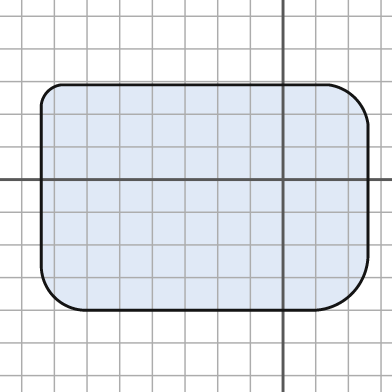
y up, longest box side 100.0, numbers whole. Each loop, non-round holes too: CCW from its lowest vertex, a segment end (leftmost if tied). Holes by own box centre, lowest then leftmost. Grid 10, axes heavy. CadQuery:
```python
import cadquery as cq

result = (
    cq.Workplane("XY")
    .moveTo(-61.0, -40.0)
    .lineTo(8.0, -40.0)
    .threePointArc((21.0, -35.0), (26.0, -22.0))
    .lineTo(26.0, 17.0)
    .threePointArc((22.0, 25.0), (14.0, 29.0))
    .lineTo(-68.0, 29.0)
    .threePointArc((-72.0, 27.0), (-74.0, 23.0))
    .lineTo(-74.0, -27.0)
    .threePointArc((-70.0, -36.0), (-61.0, -40.0))
    .close()
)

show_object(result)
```